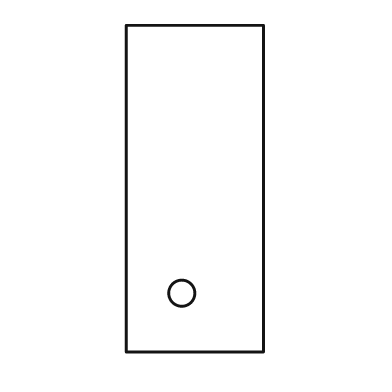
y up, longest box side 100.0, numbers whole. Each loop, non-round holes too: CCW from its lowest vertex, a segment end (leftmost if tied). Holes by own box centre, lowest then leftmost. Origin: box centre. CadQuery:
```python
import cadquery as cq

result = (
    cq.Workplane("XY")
    .moveTo(-21.0, -50.0)
    .lineTo(21.0, -50.0)
    .lineTo(21.0, 50.0)
    .lineTo(-21.0, 50.0)
    .close()
    .moveTo(-4.0, -32.0)
    .circle(4.0)
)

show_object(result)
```